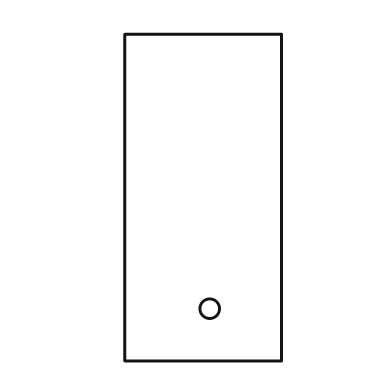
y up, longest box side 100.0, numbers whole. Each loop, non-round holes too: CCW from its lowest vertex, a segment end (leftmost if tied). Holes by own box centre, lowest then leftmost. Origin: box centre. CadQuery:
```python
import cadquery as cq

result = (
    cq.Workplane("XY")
    .moveTo(-24.0, -50.0)
    .lineTo(24.0, -50.0)
    .lineTo(24.0, 50.0)
    .lineTo(-24.0, 50.0)
    .close()
    .moveTo(2.0, -34.0)
    .circle(3.0)
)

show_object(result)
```